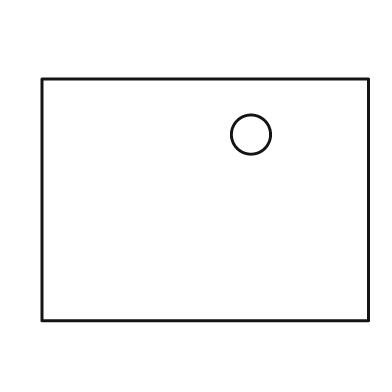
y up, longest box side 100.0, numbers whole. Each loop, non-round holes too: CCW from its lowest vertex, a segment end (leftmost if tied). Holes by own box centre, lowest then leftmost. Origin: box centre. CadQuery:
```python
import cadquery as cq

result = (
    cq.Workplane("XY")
    .moveTo(-50.0, -37.0)
    .lineTo(50.0, -37.0)
    .lineTo(50.0, 37.0)
    .lineTo(-50.0, 37.0)
    .close()
    .moveTo(14.0, 20.0)
    .circle(6.0)
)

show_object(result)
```